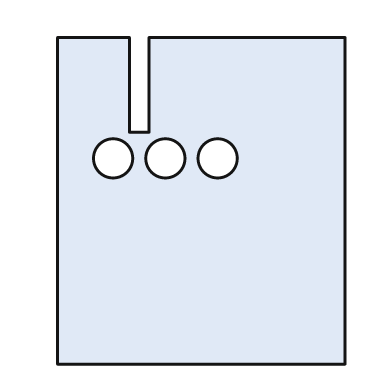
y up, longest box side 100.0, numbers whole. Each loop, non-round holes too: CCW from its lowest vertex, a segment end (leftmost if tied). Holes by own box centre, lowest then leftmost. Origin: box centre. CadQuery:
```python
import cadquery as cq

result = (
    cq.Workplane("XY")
    .moveTo(-44.0, -50.0)
    .lineTo(44.0, -50.0)
    .lineTo(44.0, 50.0)
    .lineTo(-16.0, 50.0)
    .lineTo(-16.0, 21.0)
    .lineTo(-22.0, 21.0)
    .lineTo(-22.0, 50.0)
    .lineTo(-44.0, 50.0)
    .close()
    .moveTo(-27.0, 13.0)
    .circle(6.0)
    .moveTo(-11.0, 13.0)
    .circle(6.0)
    .moveTo(5.0, 13.0)
    .circle(6.0)
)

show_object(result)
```